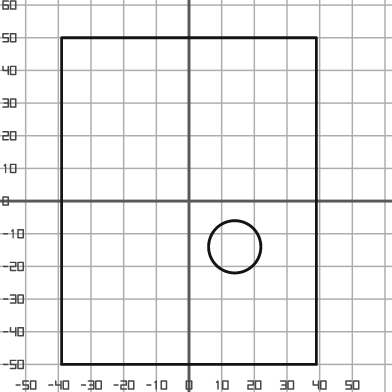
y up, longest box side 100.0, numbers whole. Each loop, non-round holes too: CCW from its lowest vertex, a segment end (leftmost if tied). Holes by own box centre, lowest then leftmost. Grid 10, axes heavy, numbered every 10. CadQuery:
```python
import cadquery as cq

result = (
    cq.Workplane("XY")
    .moveTo(-39.0, -50.0)
    .lineTo(39.0, -50.0)
    .lineTo(39.0, 50.0)
    .lineTo(-39.0, 50.0)
    .close()
    .moveTo(14.0, -14.0)
    .circle(8.0)
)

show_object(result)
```